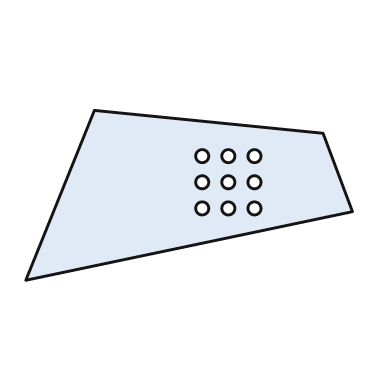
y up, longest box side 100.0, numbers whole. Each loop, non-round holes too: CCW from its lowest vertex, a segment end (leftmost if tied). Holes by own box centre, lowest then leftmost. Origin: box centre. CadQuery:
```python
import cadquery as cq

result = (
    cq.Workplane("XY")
    .moveTo(-50.0, -26.0)
    .lineTo(50.0, -5.0)
    .lineTo(41.0, 19.0)
    .lineTo(-29.0, 26.0)
    .close()
    .moveTo(4.0, -4.0)
    .circle(2.0)
    .moveTo(12.0, -4.0)
    .circle(2.0)
    .moveTo(20.0, -4.0)
    .circle(2.0)
    .moveTo(4.0, 4.0)
    .circle(2.0)
    .moveTo(12.0, 4.0)
    .circle(2.0)
    .moveTo(20.0, 4.0)
    .circle(2.0)
    .moveTo(4.0, 12.0)
    .circle(2.0)
    .moveTo(12.0, 12.0)
    .circle(2.0)
    .moveTo(20.0, 12.0)
    .circle(2.0)
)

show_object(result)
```